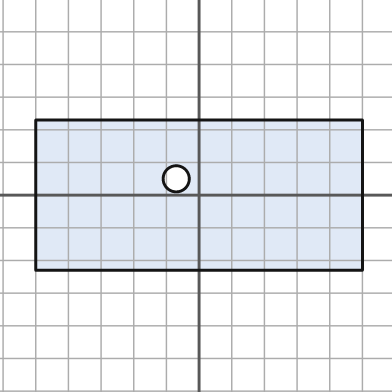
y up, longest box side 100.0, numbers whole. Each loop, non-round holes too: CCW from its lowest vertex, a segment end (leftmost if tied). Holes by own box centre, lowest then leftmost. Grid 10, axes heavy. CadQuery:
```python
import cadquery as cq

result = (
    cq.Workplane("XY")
    .moveTo(-50.0, -23.0)
    .lineTo(50.0, -23.0)
    .lineTo(50.0, 23.0)
    .lineTo(-50.0, 23.0)
    .close()
    .moveTo(-7.0, 5.0)
    .circle(4.0)
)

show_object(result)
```